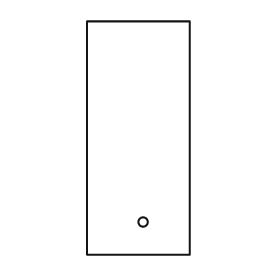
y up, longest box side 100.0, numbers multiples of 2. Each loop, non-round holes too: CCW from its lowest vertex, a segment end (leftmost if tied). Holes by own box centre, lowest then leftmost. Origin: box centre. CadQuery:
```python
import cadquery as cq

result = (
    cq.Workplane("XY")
    .moveTo(-22.0, -50.0)
    .lineTo(22.0, -50.0)
    .lineTo(22.0, 50.0)
    .lineTo(-22.0, 50.0)
    .close()
    .moveTo(2.0, -36.0)
    .circle(2.0)
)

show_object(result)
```